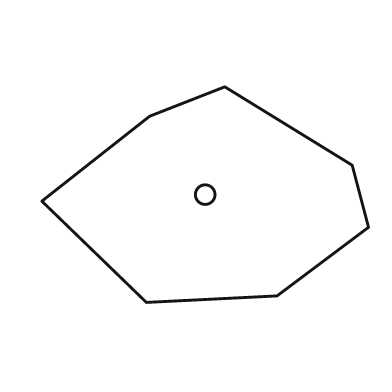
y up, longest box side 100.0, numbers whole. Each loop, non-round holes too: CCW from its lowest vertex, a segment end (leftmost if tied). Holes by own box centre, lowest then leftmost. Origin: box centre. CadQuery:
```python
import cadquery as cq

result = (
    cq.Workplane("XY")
    .moveTo(-18.0, -33.0)
    .lineTo(22.0, -31.0)
    .lineTo(50.0, -10.0)
    .lineTo(45.0, 9.0)
    .lineTo(6.0, 33.0)
    .lineTo(-17.0, 24.0)
    .lineTo(-50.0, -2.0)
    .close()
    .moveTo(0.0, 0.0)
    .circle(3.0)
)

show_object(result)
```